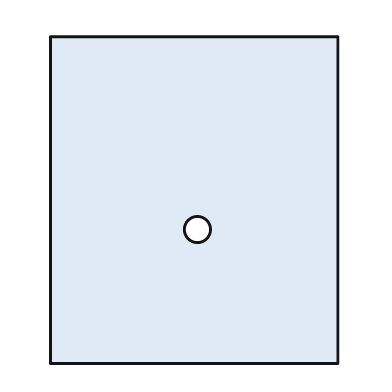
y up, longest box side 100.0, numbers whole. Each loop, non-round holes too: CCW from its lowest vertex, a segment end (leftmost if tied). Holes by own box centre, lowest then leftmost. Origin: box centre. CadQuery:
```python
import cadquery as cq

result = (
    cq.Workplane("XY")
    .moveTo(-44.0, -50.0)
    .lineTo(44.0, -50.0)
    .lineTo(44.0, 50.0)
    .lineTo(-44.0, 50.0)
    .close()
    .moveTo(1.0, -9.0)
    .circle(4.0)
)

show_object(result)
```